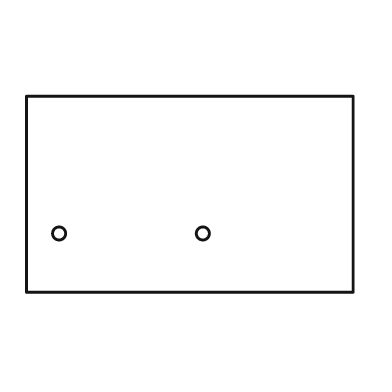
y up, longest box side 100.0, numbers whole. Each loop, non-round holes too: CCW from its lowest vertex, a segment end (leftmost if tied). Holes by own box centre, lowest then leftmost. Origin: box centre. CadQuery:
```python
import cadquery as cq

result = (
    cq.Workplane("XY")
    .moveTo(-50.0, -30.0)
    .lineTo(50.0, -30.0)
    .lineTo(50.0, 30.0)
    .lineTo(-50.0, 30.0)
    .close()
    .moveTo(-40.0, -12.0)
    .circle(2.0)
    .moveTo(4.0, -12.0)
    .circle(2.0)
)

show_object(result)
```